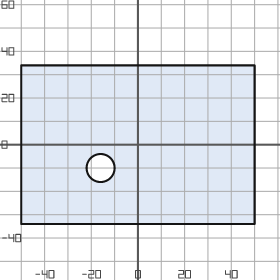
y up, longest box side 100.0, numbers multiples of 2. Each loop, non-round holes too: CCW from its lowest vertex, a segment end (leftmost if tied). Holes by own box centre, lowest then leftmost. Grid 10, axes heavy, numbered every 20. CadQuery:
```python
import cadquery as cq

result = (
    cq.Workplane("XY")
    .moveTo(-50.0, -34.0)
    .lineTo(50.0, -34.0)
    .lineTo(50.0, 34.0)
    .lineTo(-50.0, 34.0)
    .close()
    .moveTo(-16.0, -10.0)
    .circle(6.0)
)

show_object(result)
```